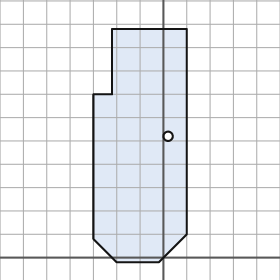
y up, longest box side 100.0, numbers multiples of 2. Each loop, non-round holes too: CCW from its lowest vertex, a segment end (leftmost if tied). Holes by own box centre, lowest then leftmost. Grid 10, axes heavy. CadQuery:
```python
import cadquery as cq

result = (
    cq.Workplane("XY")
    .moveTo(-20.0, -2.0)
    .lineTo(-2.0, -2.0)
    .lineTo(10.0, 10.0)
    .lineTo(10.0, 98.0)
    .lineTo(-22.0, 98.0)
    .lineTo(-22.0, 70.0)
    .lineTo(-30.0, 70.0)
    .lineTo(-30.0, 8.0)
    .close()
    .moveTo(2.0, 52.0)
    .circle(2.0)
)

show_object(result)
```